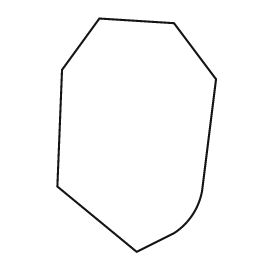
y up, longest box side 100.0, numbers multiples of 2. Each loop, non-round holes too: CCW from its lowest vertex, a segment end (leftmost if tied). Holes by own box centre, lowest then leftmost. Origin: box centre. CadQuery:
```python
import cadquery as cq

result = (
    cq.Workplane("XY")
    .moveTo(0.0, -50.0)
    .lineTo(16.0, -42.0)
    .threePointArc((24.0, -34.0), (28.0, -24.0))
    .lineTo(34.0, 24.0)
    .lineTo(16.0, 48.0)
    .lineTo(-16.0, 50.0)
    .lineTo(-32.0, 28.0)
    .lineTo(-34.0, -22.0)
    .close()
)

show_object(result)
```